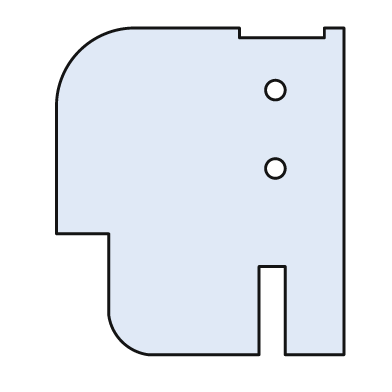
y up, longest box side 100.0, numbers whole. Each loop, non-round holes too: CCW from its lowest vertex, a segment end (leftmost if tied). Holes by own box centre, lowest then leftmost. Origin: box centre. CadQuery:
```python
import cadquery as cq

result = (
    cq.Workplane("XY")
    .moveTo(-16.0, -50.0)
    .lineTo(18.0, -50.0)
    .lineTo(18.0, -23.0)
    .lineTo(26.0, -23.0)
    .lineTo(26.0, -50.0)
    .lineTo(44.0, -50.0)
    .lineTo(44.0, 50.0)
    .lineTo(38.0, 50.0)
    .lineTo(38.0, 47.0)
    .lineTo(12.0, 47.0)
    .lineTo(12.0, 50.0)
    .lineTo(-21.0, 50.0)
    .threePointArc((-37.0, 43.0), (-44.0, 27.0))
    .lineTo(-44.0, -13.0)
    .lineTo(-28.0, -13.0)
    .lineTo(-28.0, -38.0)
    .threePointArc((-24.0, -46.0), (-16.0, -50.0))
    .close()
    .moveTo(23.0, 7.0)
    .circle(3.0)
    .moveTo(23.0, 31.0)
    .circle(3.0)
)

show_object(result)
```